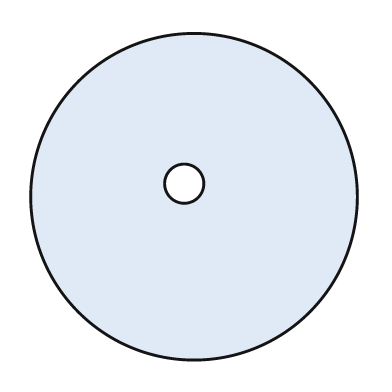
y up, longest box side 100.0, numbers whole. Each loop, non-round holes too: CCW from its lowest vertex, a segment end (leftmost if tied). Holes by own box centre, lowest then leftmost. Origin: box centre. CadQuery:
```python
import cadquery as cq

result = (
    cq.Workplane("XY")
    .moveTo(0.0, 0.0)
    .circle(50.0)
    .moveTo(-3.0, 4.0)
    .circle(6.0)
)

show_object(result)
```